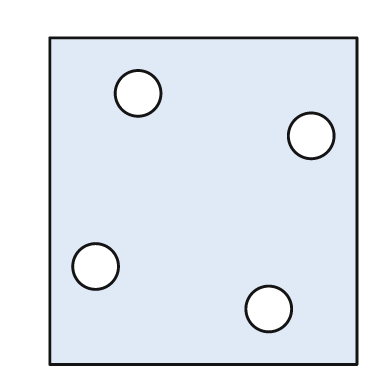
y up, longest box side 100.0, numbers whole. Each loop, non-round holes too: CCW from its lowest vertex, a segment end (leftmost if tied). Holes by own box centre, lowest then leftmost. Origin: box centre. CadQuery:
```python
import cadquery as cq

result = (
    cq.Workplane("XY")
    .moveTo(-47.0, -50.0)
    .lineTo(47.0, -50.0)
    .lineTo(47.0, 50.0)
    .lineTo(-47.0, 50.0)
    .close()
    .moveTo(20.0, -33.0)
    .circle(7.0)
    .moveTo(-33.0, -20.0)
    .circle(7.0)
    .moveTo(33.0, 20.0)
    .circle(7.0)
    .moveTo(-20.0, 33.0)
    .circle(7.0)
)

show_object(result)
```